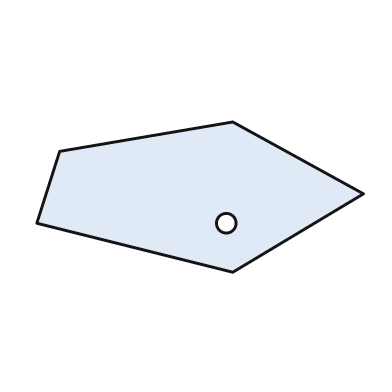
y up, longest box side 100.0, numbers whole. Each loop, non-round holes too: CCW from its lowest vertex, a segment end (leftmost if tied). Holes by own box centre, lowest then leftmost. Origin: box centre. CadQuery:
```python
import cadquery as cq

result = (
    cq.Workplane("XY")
    .moveTo(10.0, -23.0)
    .lineTo(50.0, 1.0)
    .lineTo(10.0, 23.0)
    .lineTo(-43.0, 14.0)
    .lineTo(-50.0, -8.0)
    .close()
    .moveTo(8.0, -8.0)
    .circle(3.0)
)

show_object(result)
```